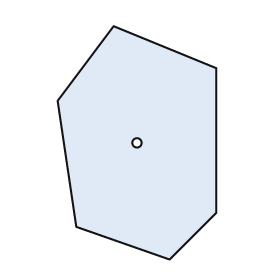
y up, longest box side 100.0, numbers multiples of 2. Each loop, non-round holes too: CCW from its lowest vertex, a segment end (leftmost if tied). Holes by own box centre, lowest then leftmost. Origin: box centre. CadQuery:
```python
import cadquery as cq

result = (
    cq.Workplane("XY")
    .moveTo(14.0, -50.0)
    .lineTo(34.0, -30.0)
    .lineTo(34.0, 32.0)
    .lineTo(-10.0, 50.0)
    .lineTo(-34.0, 18.0)
    .lineTo(-26.0, -36.0)
    .close()
    .moveTo(0.0, 0.0)
    .circle(2.0)
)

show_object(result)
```